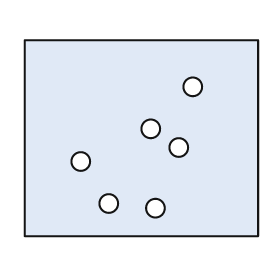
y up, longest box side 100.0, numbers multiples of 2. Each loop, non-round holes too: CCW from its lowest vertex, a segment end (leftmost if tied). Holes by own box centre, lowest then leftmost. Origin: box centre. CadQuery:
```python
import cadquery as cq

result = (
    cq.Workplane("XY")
    .moveTo(-50.0, -42.0)
    .lineTo(50.0, -42.0)
    .lineTo(50.0, 42.0)
    .lineTo(-50.0, 42.0)
    .close()
    .moveTo(6.0, -30.0)
    .circle(4.0)
    .moveTo(-14.0, -28.0)
    .circle(4.0)
    .moveTo(-26.0, -10.0)
    .circle(4.0)
    .moveTo(16.0, -4.0)
    .circle(4.0)
    .moveTo(4.0, 4.0)
    .circle(4.0)
    .moveTo(22.0, 22.0)
    .circle(4.0)
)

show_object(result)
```